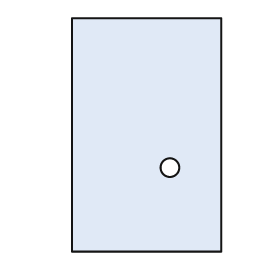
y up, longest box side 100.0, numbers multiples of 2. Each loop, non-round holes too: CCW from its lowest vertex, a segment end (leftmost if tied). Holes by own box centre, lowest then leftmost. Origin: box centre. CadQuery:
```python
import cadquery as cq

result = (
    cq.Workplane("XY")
    .moveTo(-32.0, -50.0)
    .lineTo(32.0, -50.0)
    .lineTo(32.0, 50.0)
    .lineTo(-32.0, 50.0)
    .close()
    .moveTo(10.0, -14.0)
    .circle(4.0)
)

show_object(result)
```